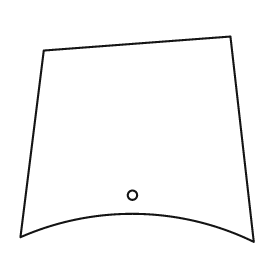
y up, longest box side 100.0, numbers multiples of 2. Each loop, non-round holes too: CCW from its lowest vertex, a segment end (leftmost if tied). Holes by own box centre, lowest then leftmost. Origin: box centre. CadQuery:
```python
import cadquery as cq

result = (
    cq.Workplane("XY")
    .moveTo(50.0, -44.0)
    .lineTo(40.0, 44.0)
    .lineTo(-40.0, 38.0)
    .lineTo(-50.0, -42.0)
    .threePointArc((0.0, -32.0), (50.0, -44.0))
    .close()
    .moveTo(-2.0, -24.0)
    .circle(2.0)
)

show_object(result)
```